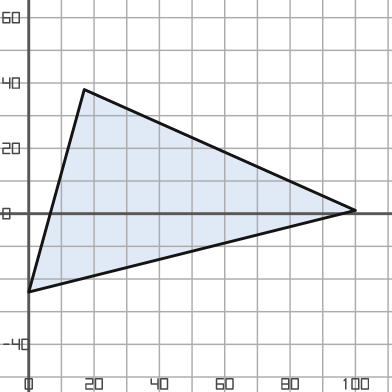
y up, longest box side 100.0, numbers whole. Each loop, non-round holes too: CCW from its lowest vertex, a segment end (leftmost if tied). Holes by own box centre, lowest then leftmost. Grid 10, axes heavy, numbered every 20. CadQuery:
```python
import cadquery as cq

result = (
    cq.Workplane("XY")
    .moveTo(0.0, -24.0)
    .lineTo(100.0, 1.0)
    .lineTo(17.0, 38.0)
    .close()
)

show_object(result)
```